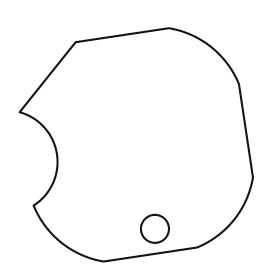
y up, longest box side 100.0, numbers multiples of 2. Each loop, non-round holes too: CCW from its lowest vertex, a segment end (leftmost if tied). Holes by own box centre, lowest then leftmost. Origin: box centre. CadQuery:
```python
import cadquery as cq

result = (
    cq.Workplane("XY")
    .moveTo(-14.0, -50.0)
    .lineTo(26.0, -44.0)
    .threePointArc((42.0, -32.0), (50.0, -14.0))
    .lineTo(44.0, 26.0)
    .threePointArc((32.0, 42.0), (14.0, 50.0))
    .lineTo(-26.0, 44.0)
    .lineTo(-50.0, 14.0)
    .threePointArc((-34.0, -4.0), (-44.0, -26.0))
    .threePointArc((-32.0, -42.0), (-14.0, -50.0))
    .close()
    .moveTo(8.0, -36.0)
    .circle(6.0)
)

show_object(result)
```